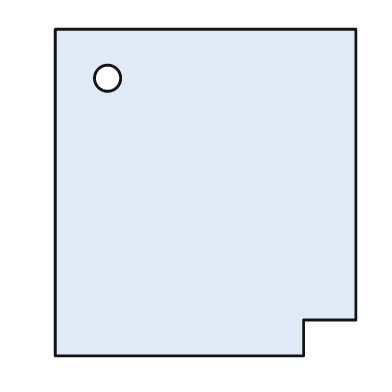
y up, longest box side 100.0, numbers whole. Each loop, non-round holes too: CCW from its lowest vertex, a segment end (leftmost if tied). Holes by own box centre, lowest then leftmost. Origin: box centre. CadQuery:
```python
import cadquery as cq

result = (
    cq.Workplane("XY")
    .moveTo(-46.0, -50.0)
    .lineTo(30.0, -50.0)
    .lineTo(30.0, -39.0)
    .lineTo(46.0, -39.0)
    .lineTo(46.0, 50.0)
    .lineTo(-46.0, 50.0)
    .close()
    .moveTo(-30.0, 35.0)
    .circle(4.0)
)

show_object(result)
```